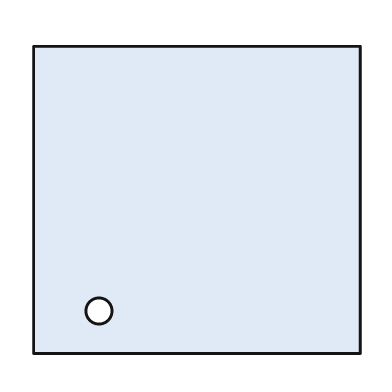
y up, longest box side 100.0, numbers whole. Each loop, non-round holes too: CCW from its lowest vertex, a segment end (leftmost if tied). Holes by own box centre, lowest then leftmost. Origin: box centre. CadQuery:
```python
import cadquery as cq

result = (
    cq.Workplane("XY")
    .moveTo(-50.0, -47.0)
    .lineTo(50.0, -47.0)
    .lineTo(50.0, 47.0)
    .lineTo(-50.0, 47.0)
    .close()
    .moveTo(-30.0, -34.0)
    .circle(4.0)
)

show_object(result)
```